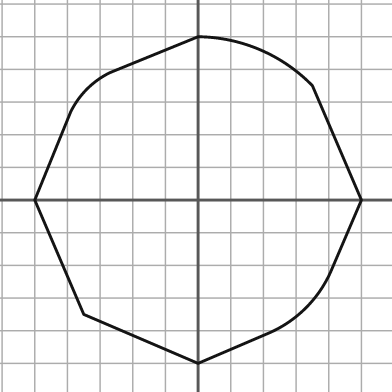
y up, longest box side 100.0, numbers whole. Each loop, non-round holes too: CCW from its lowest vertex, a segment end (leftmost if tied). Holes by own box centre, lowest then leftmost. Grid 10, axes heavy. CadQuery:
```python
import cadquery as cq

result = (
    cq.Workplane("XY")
    .moveTo(0.0, -50.0)
    .lineTo(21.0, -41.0)
    .threePointArc((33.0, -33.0), (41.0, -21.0))
    .lineTo(50.0, 0.0)
    .lineTo(35.0, 35.0)
    .threePointArc((19.0, 46.0), (0.0, 50.0))
    .lineTo(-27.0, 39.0)
    .threePointArc((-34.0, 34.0), (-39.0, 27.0))
    .lineTo(-50.0, 0.0)
    .lineTo(-35.0, -35.0)
    .close()
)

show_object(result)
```